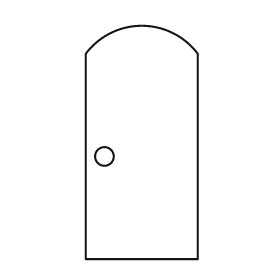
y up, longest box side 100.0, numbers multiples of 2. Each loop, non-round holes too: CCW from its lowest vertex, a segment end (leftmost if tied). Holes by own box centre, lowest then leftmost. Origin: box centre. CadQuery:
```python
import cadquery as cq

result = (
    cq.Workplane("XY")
    .moveTo(-24.0, -50.0)
    .lineTo(24.0, -50.0)
    .lineTo(24.0, 38.0)
    .threePointArc((0.0, 50.0), (-24.0, 38.0))
    .close()
    .moveTo(-16.0, -6.0)
    .circle(4.0)
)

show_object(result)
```